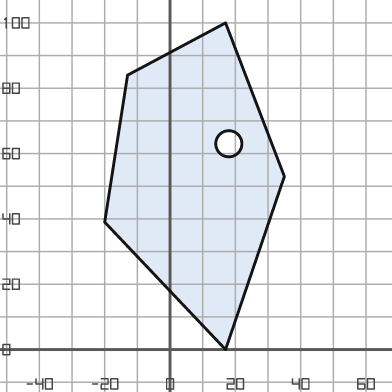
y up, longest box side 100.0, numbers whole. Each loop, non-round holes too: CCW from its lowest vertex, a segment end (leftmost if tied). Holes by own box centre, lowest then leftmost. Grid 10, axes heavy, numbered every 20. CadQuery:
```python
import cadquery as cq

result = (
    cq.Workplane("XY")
    .moveTo(17.0, 0.0)
    .lineTo(35.0, 53.0)
    .lineTo(17.0, 100.0)
    .lineTo(-13.0, 84.0)
    .lineTo(-20.0, 39.0)
    .close()
    .moveTo(18.0, 63.0)
    .circle(4.0)
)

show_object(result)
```